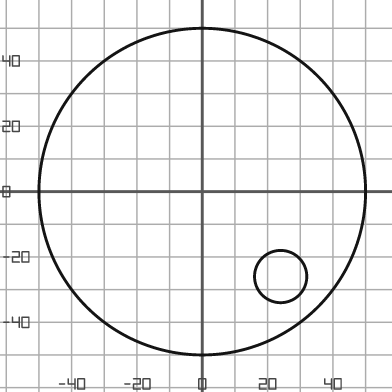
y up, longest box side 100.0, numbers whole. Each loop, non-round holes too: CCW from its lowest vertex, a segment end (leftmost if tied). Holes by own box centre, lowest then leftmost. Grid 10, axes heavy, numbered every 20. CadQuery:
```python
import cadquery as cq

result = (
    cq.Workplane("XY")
    .moveTo(0.0, 0.0)
    .circle(50.0)
    .moveTo(24.0, -26.0)
    .circle(8.0)
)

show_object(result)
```